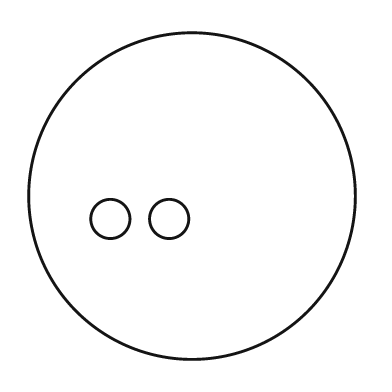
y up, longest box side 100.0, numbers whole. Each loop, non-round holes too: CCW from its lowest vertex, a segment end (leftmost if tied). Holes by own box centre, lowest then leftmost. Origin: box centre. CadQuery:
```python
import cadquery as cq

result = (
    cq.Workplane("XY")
    .moveTo(0.0, 0.0)
    .circle(50.0)
    .moveTo(-25.0, -7.0)
    .circle(6.0)
    .moveTo(-7.0, -7.0)
    .circle(6.0)
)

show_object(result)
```